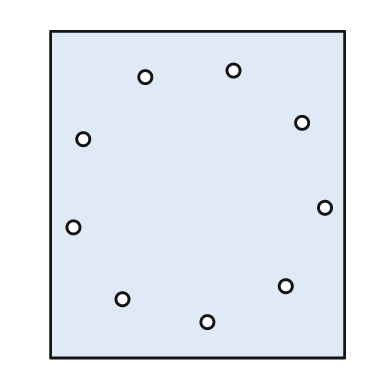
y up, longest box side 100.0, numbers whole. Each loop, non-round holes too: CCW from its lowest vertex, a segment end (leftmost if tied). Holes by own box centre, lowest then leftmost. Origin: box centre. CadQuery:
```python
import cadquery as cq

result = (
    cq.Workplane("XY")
    .moveTo(-45.0, -50.0)
    .lineTo(45.0, -50.0)
    .lineTo(45.0, 50.0)
    .lineTo(-45.0, 50.0)
    .close()
    .moveTo(3.0, -39.0)
    .circle(2.0)
    .moveTo(-23.0, -32.0)
    .circle(2.0)
    .moveTo(27.0, -28.0)
    .circle(2.0)
    .moveTo(-38.0, -10.0)
    .circle(2.0)
    .moveTo(39.0, -4.0)
    .circle(2.0)
    .moveTo(-35.0, 17.0)
    .circle(2.0)
    .moveTo(32.0, 22.0)
    .circle(2.0)
    .moveTo(-16.0, 36.0)
    .circle(2.0)
    .moveTo(11.0, 38.0)
    .circle(2.0)
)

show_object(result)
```